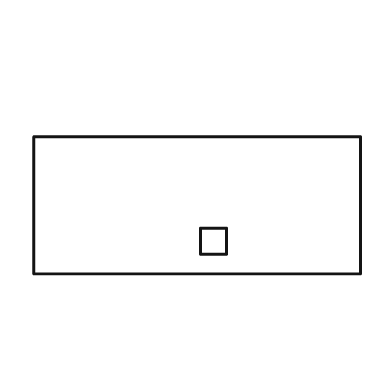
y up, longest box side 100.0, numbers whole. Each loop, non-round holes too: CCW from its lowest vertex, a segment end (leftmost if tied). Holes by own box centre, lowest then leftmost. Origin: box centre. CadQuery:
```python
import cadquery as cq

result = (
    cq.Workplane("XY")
    .moveTo(-50.0, -21.0)
    .lineTo(50.0, -21.0)
    .lineTo(50.0, 21.0)
    .lineTo(-50.0, 21.0)
    .close()
    .moveTo(1.0, -15.0)
    .lineTo(9.0, -15.0)
    .lineTo(9.0, -7.0)
    .lineTo(1.0, -7.0)
    .close()
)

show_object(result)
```